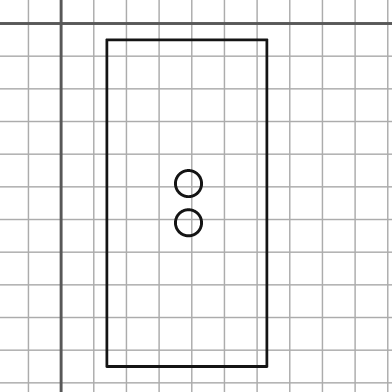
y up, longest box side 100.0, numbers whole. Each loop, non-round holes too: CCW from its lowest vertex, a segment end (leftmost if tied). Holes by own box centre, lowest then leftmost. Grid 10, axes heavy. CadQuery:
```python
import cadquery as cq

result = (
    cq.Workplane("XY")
    .moveTo(14.0, -105.0)
    .lineTo(63.0, -105.0)
    .lineTo(63.0, -5.0)
    .lineTo(14.0, -5.0)
    .close()
    .moveTo(39.0, -61.0)
    .circle(4.0)
    .moveTo(39.0, -49.0)
    .circle(4.0)
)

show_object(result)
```